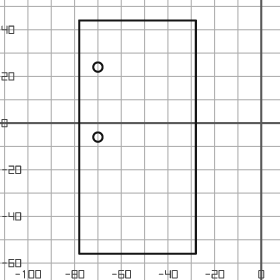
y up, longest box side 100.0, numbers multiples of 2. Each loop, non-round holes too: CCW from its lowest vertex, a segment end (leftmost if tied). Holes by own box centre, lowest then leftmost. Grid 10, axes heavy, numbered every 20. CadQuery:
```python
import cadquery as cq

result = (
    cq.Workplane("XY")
    .moveTo(-78.0, -56.0)
    .lineTo(-28.0, -56.0)
    .lineTo(-28.0, 44.0)
    .lineTo(-78.0, 44.0)
    .close()
    .moveTo(-70.0, -6.0)
    .circle(2.0)
    .moveTo(-70.0, 24.0)
    .circle(2.0)
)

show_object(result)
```